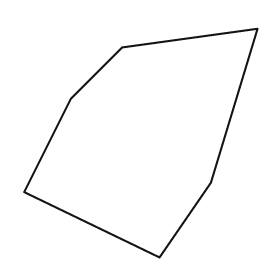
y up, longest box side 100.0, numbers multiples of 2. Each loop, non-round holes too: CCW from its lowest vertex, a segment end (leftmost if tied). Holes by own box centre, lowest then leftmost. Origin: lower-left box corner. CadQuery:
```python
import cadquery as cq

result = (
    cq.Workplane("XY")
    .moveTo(58.0, 0.0)
    .lineTo(80.0, 32.0)
    .lineTo(100.0, 98.0)
    .lineTo(42.0, 90.0)
    .lineTo(20.0, 68.0)
    .lineTo(0.0, 28.0)
    .close()
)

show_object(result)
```